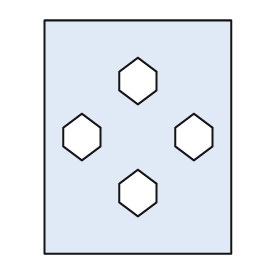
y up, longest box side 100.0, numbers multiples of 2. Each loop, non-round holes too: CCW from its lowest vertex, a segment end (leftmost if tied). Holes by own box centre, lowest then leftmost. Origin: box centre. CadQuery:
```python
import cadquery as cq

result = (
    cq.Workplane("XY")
    .moveTo(-40.0, -50.0)
    .lineTo(40.0, -50.0)
    .lineTo(40.0, 50.0)
    .lineTo(-40.0, 50.0)
    .close()
    .moveTo(0.0, -34.0)
    .lineTo(8.0, -28.0)
    .lineTo(8.0, -20.0)
    .lineTo(0.0, -14.0)
    .lineTo(-8.0, -20.0)
    .lineTo(-8.0, -28.0)
    .close()
    .moveTo(-24.0, -10.0)
    .lineTo(-16.0, -4.0)
    .lineTo(-16.0, 4.0)
    .lineTo(-24.0, 10.0)
    .lineTo(-32.0, 4.0)
    .lineTo(-32.0, -4.0)
    .close()
    .moveTo(24.0, -10.0)
    .lineTo(32.0, -4.0)
    .lineTo(32.0, 4.0)
    .lineTo(24.0, 10.0)
    .lineTo(16.0, 4.0)
    .lineTo(16.0, -4.0)
    .close()
    .moveTo(0.0, 14.0)
    .lineTo(8.0, 20.0)
    .lineTo(8.0, 28.0)
    .lineTo(0.0, 34.0)
    .lineTo(-8.0, 28.0)
    .lineTo(-8.0, 20.0)
    .close()
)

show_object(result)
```